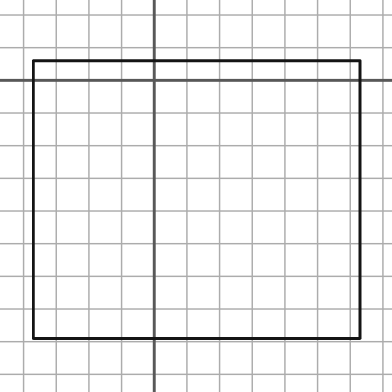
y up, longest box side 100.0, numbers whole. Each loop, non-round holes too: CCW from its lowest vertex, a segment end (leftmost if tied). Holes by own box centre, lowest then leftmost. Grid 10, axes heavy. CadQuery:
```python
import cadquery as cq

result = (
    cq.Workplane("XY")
    .moveTo(-37.0, -79.0)
    .lineTo(63.0, -79.0)
    .lineTo(63.0, 6.0)
    .lineTo(-37.0, 6.0)
    .close()
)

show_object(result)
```